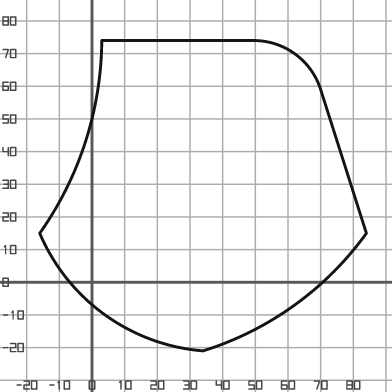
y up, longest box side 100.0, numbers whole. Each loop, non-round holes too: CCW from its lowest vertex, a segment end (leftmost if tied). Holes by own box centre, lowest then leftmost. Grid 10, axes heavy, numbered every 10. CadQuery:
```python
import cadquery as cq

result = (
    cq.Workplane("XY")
    .moveTo(34.0, -21.0)
    .threePointArc((62.0, -7.0), (84.0, 15.0))
    .lineTo(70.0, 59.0)
    .threePointArc((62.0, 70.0), (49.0, 74.0))
    .lineTo(3.0, 74.0)
    .threePointArc((-2.0, 43.0), (-16.0, 15.0))
    .threePointArc((4.0, -10.0), (34.0, -21.0))
    .close()
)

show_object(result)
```